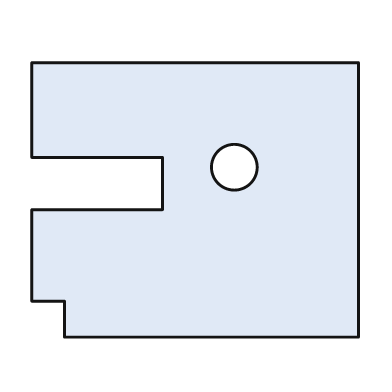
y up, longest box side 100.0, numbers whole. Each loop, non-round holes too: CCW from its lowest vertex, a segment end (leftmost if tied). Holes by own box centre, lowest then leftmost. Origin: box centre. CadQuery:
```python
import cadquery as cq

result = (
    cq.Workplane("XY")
    .moveTo(-40.0, -42.0)
    .lineTo(50.0, -42.0)
    .lineTo(50.0, 42.0)
    .lineTo(-50.0, 42.0)
    .lineTo(-50.0, 13.0)
    .lineTo(-10.0, 13.0)
    .lineTo(-10.0, -3.0)
    .lineTo(-50.0, -3.0)
    .lineTo(-50.0, -31.0)
    .lineTo(-40.0, -31.0)
    .close()
    .moveTo(12.0, 10.0)
    .circle(7.0)
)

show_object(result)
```